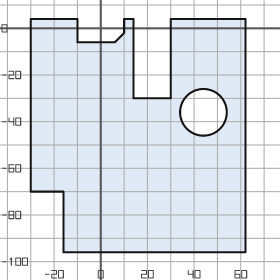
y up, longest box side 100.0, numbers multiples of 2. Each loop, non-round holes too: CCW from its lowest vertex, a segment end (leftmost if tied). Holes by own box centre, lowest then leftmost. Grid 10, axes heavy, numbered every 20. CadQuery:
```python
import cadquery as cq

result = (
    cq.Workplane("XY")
    .moveTo(-16.0, -96.0)
    .lineTo(62.0, -96.0)
    .lineTo(62.0, 4.0)
    .lineTo(30.0, 4.0)
    .lineTo(30.0, -30.0)
    .lineTo(14.0, -30.0)
    .lineTo(14.0, 4.0)
    .lineTo(10.0, 4.0)
    .lineTo(10.0, -2.0)
    .lineTo(6.0, -6.0)
    .lineTo(-10.0, -6.0)
    .lineTo(-10.0, 4.0)
    .lineTo(-30.0, 4.0)
    .lineTo(-30.0, -70.0)
    .lineTo(-16.0, -70.0)
    .close()
    .moveTo(44.0, -36.0)
    .circle(10.0)
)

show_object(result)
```